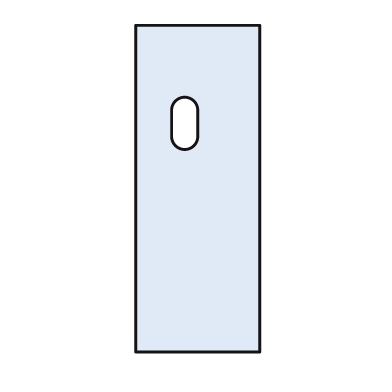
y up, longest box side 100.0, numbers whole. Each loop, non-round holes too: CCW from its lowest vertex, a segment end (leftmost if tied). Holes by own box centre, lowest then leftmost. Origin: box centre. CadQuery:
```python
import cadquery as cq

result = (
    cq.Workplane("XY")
    .moveTo(-19.0, -50.0)
    .lineTo(19.0, -50.0)
    .lineTo(19.0, 50.0)
    .lineTo(-19.0, 50.0)
    .close()
    .moveTo(-8.0, 16.0)
    .threePointArc((-4.0, 12.0), (0.0, 16.0))
    .lineTo(0.0, 24.0)
    .threePointArc((-4.0, 28.0), (-8.0, 24.0))
    .close()
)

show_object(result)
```